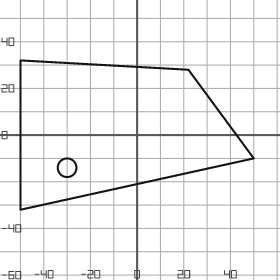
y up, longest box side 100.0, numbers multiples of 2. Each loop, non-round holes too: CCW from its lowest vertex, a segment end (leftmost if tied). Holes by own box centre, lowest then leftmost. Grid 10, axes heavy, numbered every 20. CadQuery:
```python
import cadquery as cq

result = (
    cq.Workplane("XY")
    .moveTo(-50.0, -32.0)
    .lineTo(50.0, -10.0)
    .lineTo(22.0, 28.0)
    .lineTo(-50.0, 32.0)
    .close()
    .moveTo(-30.0, -14.0)
    .circle(4.0)
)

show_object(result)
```